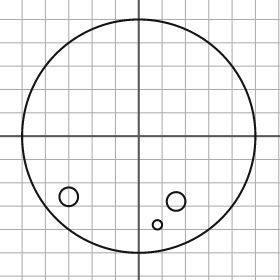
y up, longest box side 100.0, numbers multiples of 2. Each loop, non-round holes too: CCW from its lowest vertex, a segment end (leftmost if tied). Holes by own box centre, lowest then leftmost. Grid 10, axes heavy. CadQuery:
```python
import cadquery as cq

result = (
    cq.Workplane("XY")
    .moveTo(0.0, 0.0)
    .circle(50.0)
    .moveTo(8.0, -38.0)
    .circle(2.0)
    .moveTo(16.0, -28.0)
    .circle(4.0)
    .moveTo(-30.0, -26.0)
    .circle(4.0)
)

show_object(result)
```